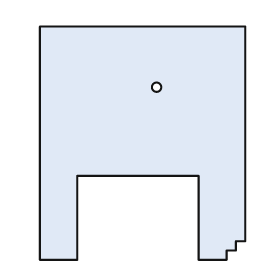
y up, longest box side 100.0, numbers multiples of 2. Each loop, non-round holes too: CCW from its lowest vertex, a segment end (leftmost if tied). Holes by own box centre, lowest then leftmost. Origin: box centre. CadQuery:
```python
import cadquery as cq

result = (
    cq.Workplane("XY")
    .moveTo(-44.0, -50.0)
    .lineTo(-28.0, -50.0)
    .lineTo(-28.0, -14.0)
    .lineTo(24.0, -14.0)
    .lineTo(24.0, -50.0)
    .lineTo(36.0, -50.0)
    .lineTo(36.0, -46.0)
    .lineTo(40.0, -46.0)
    .lineTo(40.0, -42.0)
    .lineTo(44.0, -42.0)
    .lineTo(44.0, 50.0)
    .lineTo(-44.0, 50.0)
    .close()
    .moveTo(6.0, 24.0)
    .circle(2.0)
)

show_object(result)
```